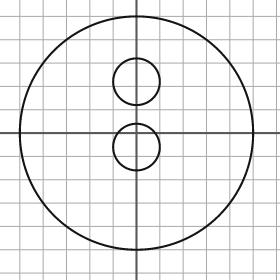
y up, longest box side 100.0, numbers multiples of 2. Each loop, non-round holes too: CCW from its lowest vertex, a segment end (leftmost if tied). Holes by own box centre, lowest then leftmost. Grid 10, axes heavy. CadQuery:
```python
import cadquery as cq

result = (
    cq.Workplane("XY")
    .moveTo(0.0, 0.0)
    .circle(50.0)
    .moveTo(0.0, -6.0)
    .circle(10.0)
    .moveTo(0.0, 22.0)
    .circle(10.0)
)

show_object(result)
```